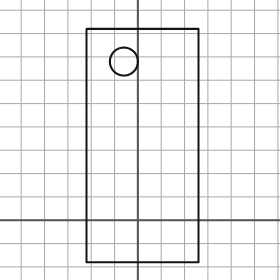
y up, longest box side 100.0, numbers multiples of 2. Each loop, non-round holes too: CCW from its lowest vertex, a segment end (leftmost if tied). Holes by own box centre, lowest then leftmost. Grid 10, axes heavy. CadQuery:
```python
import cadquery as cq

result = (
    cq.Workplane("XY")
    .moveTo(-22.0, -18.0)
    .lineTo(26.0, -18.0)
    .lineTo(26.0, 82.0)
    .lineTo(-22.0, 82.0)
    .close()
    .moveTo(-6.0, 68.0)
    .circle(6.0)
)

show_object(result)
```